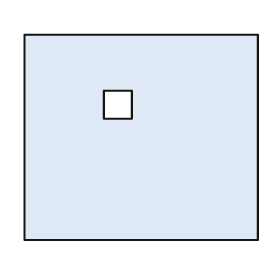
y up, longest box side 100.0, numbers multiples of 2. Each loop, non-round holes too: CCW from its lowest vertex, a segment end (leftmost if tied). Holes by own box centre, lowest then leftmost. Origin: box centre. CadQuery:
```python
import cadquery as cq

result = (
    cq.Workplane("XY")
    .moveTo(-50.0, -44.0)
    .lineTo(50.0, -44.0)
    .lineTo(50.0, 44.0)
    .lineTo(-50.0, 44.0)
    .close()
    .moveTo(-16.0, 8.0)
    .lineTo(-4.0, 8.0)
    .lineTo(-4.0, 20.0)
    .lineTo(-16.0, 20.0)
    .close()
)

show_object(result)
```